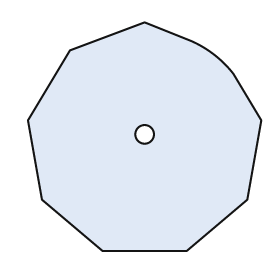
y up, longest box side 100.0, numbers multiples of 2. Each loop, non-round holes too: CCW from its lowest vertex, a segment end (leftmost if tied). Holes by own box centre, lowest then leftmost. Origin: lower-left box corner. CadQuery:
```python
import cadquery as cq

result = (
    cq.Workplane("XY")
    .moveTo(32.0, 0.0)
    .lineTo(68.0, 0.0)
    .lineTo(94.0, 22.0)
    .lineTo(100.0, 56.0)
    .lineTo(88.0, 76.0)
    .threePointArc((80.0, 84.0), (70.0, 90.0))
    .lineTo(50.0, 98.0)
    .lineTo(18.0, 86.0)
    .lineTo(0.0, 56.0)
    .lineTo(6.0, 22.0)
    .close()
    .moveTo(50.0, 50.0)
    .circle(4.0)
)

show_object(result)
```